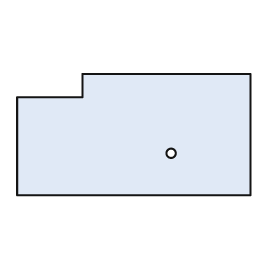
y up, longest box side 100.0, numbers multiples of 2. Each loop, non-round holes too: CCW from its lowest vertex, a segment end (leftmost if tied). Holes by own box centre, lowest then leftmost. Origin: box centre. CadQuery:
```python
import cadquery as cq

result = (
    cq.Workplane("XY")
    .moveTo(-50.0, -26.0)
    .lineTo(50.0, -26.0)
    .lineTo(50.0, 26.0)
    .lineTo(-22.0, 26.0)
    .lineTo(-22.0, 16.0)
    .lineTo(-50.0, 16.0)
    .close()
    .moveTo(16.0, -8.0)
    .circle(2.0)
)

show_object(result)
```